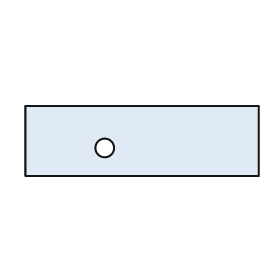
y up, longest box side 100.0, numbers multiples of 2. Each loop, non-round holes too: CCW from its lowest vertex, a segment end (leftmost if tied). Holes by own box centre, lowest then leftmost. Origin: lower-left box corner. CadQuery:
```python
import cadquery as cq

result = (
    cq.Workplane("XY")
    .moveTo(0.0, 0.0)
    .lineTo(100.0, 0.0)
    .lineTo(100.0, 30.0)
    .lineTo(0.0, 30.0)
    .close()
    .moveTo(34.0, 12.0)
    .circle(4.0)
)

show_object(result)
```